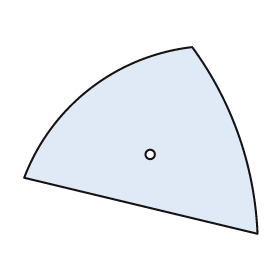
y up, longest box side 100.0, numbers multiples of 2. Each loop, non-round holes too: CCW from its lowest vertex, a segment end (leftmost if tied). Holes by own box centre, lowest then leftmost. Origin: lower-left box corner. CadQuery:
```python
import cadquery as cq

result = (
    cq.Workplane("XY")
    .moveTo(100.0, 0.0)
    .threePointArc((92.0, 42.0), (72.0, 80.0))
    .threePointArc((28.0, 62.0), (0.0, 24.0))
    .close()
    .moveTo(54.0, 34.0)
    .circle(2.0)
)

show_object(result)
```